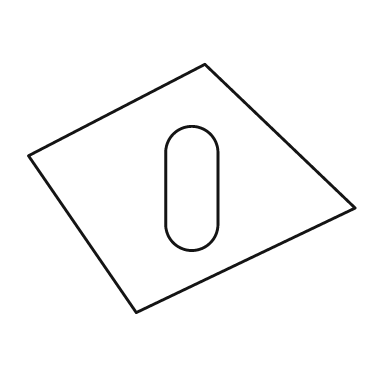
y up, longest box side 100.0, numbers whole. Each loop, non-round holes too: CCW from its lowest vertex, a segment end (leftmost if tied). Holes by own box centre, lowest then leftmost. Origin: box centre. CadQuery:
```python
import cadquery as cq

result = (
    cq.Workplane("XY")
    .moveTo(-17.0, -38.0)
    .lineTo(50.0, -6.0)
    .lineTo(4.0, 38.0)
    .lineTo(-50.0, 10.0)
    .close()
    .moveTo(-8.0, -11.0)
    .threePointArc((0.0, -19.0), (8.0, -11.0))
    .lineTo(8.0, 11.0)
    .threePointArc((0.0, 19.0), (-8.0, 11.0))
    .close()
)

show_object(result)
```